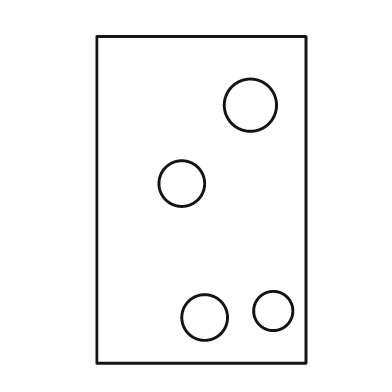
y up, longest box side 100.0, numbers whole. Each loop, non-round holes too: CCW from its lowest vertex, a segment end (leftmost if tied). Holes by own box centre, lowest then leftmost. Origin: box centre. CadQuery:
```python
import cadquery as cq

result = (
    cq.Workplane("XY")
    .moveTo(-32.0, -50.0)
    .lineTo(32.0, -50.0)
    .lineTo(32.0, 50.0)
    .lineTo(-32.0, 50.0)
    .close()
    .moveTo(1.0, -36.0)
    .circle(7.0)
    .moveTo(22.0, -34.0)
    .circle(6.0)
    .moveTo(-6.0, 5.0)
    .circle(7.0)
    .moveTo(15.0, 29.0)
    .circle(8.0)
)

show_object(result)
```